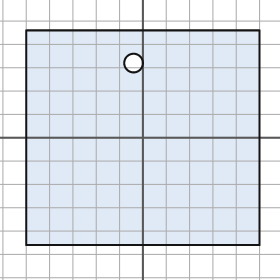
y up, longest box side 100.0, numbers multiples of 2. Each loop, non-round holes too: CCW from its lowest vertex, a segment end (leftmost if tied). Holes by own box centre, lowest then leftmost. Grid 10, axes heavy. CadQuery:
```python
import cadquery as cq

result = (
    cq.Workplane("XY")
    .moveTo(-50.0, -46.0)
    .lineTo(50.0, -46.0)
    .lineTo(50.0, 46.0)
    .lineTo(-50.0, 46.0)
    .close()
    .moveTo(-4.0, 32.0)
    .circle(4.0)
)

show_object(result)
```